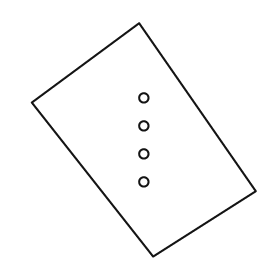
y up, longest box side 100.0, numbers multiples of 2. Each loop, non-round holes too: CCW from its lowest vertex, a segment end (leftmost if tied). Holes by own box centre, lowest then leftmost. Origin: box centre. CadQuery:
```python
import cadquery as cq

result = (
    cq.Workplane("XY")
    .moveTo(4.0, -50.0)
    .lineTo(48.0, -22.0)
    .lineTo(-2.0, 50.0)
    .lineTo(-48.0, 16.0)
    .close()
    .moveTo(0.0, -18.0)
    .circle(2.0)
    .moveTo(0.0, -6.0)
    .circle(2.0)
    .moveTo(0.0, 6.0)
    .circle(2.0)
    .moveTo(0.0, 18.0)
    .circle(2.0)
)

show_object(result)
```